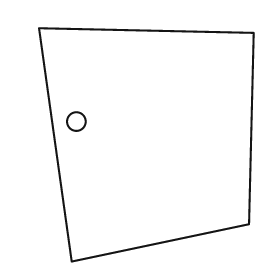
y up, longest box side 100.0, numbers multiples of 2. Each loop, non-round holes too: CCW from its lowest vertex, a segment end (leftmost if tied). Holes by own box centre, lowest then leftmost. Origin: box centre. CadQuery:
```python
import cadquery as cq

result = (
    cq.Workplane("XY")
    .moveTo(-32.0, -50.0)
    .lineTo(44.0, -34.0)
    .lineTo(46.0, 48.0)
    .lineTo(-46.0, 50.0)
    .close()
    .moveTo(-30.0, 10.0)
    .circle(4.0)
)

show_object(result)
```